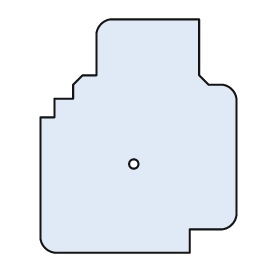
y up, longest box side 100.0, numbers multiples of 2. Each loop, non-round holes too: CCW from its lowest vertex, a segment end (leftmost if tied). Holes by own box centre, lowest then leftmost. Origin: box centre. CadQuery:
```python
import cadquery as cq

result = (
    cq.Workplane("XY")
    .moveTo(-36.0, -50.0)
    .lineTo(22.0, -50.0)
    .lineTo(22.0, -40.0)
    .lineTo(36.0, -40.0)
    .threePointArc((40.0, -38.0), (42.0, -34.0))
    .lineTo(42.0, 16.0)
    .threePointArc((40.0, 20.0), (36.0, 22.0))
    .lineTo(30.0, 22.0)
    .lineTo(26.0, 26.0)
    .lineTo(26.0, 50.0)
    .lineTo(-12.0, 50.0)
    .threePointArc((-16.0, 48.0), (-18.0, 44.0))
    .lineTo(-18.0, 26.0)
    .lineTo(-24.0, 26.0)
    .lineTo(-28.0, 22.0)
    .lineTo(-28.0, 16.0)
    .lineTo(-36.0, 16.0)
    .lineTo(-36.0, 8.0)
    .lineTo(-42.0, 8.0)
    .lineTo(-42.0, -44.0)
    .threePointArc((-40.0, -48.0), (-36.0, -50.0))
    .close()
    .moveTo(-2.0, -12.0)
    .circle(2.0)
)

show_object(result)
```